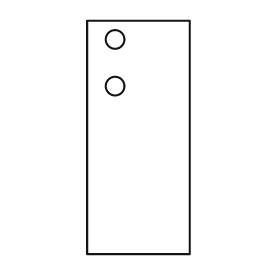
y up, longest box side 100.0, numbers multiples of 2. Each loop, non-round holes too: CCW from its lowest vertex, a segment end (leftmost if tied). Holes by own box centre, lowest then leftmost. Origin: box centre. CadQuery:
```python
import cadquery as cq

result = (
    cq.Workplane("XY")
    .moveTo(-22.0, -50.0)
    .lineTo(22.0, -50.0)
    .lineTo(22.0, 50.0)
    .lineTo(-22.0, 50.0)
    .close()
    .moveTo(-10.0, 22.0)
    .circle(4.0)
    .moveTo(-10.0, 42.0)
    .circle(4.0)
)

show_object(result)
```